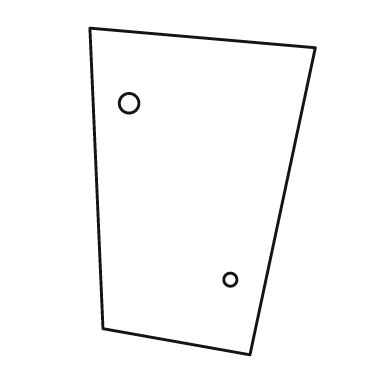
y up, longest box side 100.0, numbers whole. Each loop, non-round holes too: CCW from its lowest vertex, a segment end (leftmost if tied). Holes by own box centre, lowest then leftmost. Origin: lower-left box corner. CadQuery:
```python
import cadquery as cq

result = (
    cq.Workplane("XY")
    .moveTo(49.0, 0.0)
    .lineTo(69.0, 94.0)
    .lineTo(0.0, 100.0)
    .lineTo(4.0, 8.0)
    .close()
    .moveTo(43.0, 23.0)
    .circle(2.0)
    .moveTo(12.0, 77.0)
    .circle(3.0)
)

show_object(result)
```